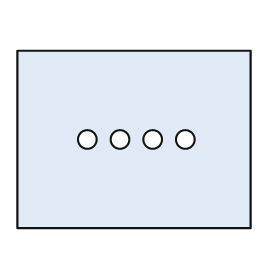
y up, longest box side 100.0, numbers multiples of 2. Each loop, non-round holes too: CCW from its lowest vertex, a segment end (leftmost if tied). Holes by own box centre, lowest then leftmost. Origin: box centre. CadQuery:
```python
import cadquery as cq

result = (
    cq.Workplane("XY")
    .moveTo(-50.0, -38.0)
    .lineTo(50.0, -38.0)
    .lineTo(50.0, 38.0)
    .lineTo(-50.0, 38.0)
    .close()
    .moveTo(-20.0, 0.0)
    .circle(4.0)
    .moveTo(-6.0, 0.0)
    .circle(4.0)
    .moveTo(8.0, 0.0)
    .circle(4.0)
    .moveTo(22.0, 0.0)
    .circle(4.0)
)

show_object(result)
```